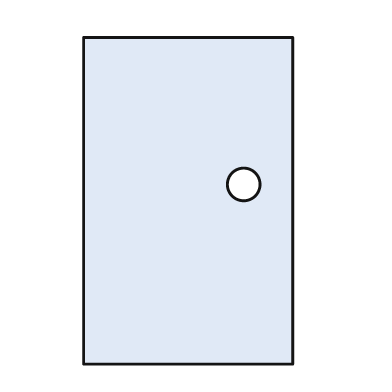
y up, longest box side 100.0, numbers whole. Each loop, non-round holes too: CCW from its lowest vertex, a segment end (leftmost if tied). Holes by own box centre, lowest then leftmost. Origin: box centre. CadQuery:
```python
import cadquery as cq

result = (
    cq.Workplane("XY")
    .moveTo(-32.0, -50.0)
    .lineTo(32.0, -50.0)
    .lineTo(32.0, 50.0)
    .lineTo(-32.0, 50.0)
    .close()
    .moveTo(17.0, 5.0)
    .circle(5.0)
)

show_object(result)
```